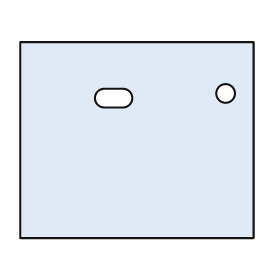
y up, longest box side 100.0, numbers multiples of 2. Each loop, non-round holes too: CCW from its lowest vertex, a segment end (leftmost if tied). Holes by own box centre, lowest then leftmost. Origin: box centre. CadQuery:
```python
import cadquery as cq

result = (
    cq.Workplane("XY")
    .moveTo(-50.0, -42.0)
    .lineTo(50.0, -42.0)
    .lineTo(50.0, 42.0)
    .lineTo(-50.0, 42.0)
    .close()
    .moveTo(-14.0, 14.0)
    .lineTo(-6.0, 14.0)
    .threePointArc((-2.0, 18.0), (-6.0, 22.0))
    .lineTo(-14.0, 22.0)
    .threePointArc((-18.0, 18.0), (-14.0, 14.0))
    .close()
    .moveTo(38.0, 20.0)
    .circle(4.0)
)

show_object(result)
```